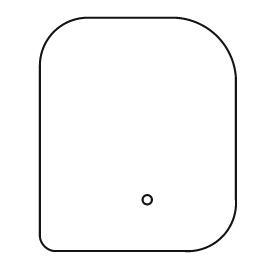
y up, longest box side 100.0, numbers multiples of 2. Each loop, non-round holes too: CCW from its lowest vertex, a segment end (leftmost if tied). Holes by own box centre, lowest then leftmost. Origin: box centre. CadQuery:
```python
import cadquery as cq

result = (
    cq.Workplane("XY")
    .moveTo(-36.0, -50.0)
    .lineTo(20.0, -50.0)
    .threePointArc((36.0, -44.0), (42.0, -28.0))
    .lineTo(42.0, 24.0)
    .threePointArc((34.0, 42.0), (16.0, 50.0))
    .lineTo(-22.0, 50.0)
    .threePointArc((-36.0, 44.0), (-42.0, 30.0))
    .lineTo(-42.0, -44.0)
    .threePointArc((-40.0, -48.0), (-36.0, -50.0))
    .close()
    .moveTo(4.0, -28.0)
    .circle(2.0)
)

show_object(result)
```